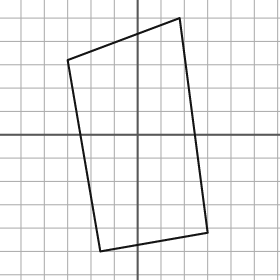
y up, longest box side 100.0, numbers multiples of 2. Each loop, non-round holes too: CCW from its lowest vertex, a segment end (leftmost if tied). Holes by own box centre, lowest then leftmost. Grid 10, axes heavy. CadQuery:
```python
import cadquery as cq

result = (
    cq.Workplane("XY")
    .moveTo(-16.0, -50.0)
    .lineTo(30.0, -42.0)
    .lineTo(18.0, 50.0)
    .lineTo(-30.0, 32.0)
    .close()
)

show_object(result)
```